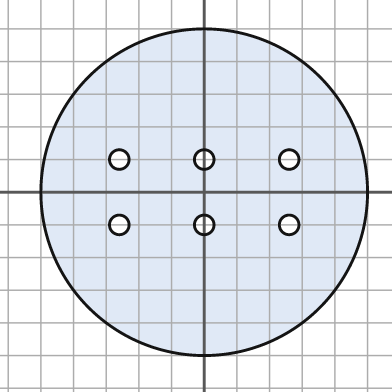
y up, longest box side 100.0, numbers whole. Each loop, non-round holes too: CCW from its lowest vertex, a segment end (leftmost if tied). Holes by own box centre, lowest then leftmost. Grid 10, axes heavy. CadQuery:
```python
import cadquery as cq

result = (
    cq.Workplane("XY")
    .moveTo(0.0, 0.0)
    .circle(50.0)
    .moveTo(-26.0, -10.0)
    .circle(3.0)
    .moveTo(0.0, -10.0)
    .circle(3.0)
    .moveTo(26.0, -10.0)
    .circle(3.0)
    .moveTo(-26.0, 10.0)
    .circle(3.0)
    .moveTo(0.0, 10.0)
    .circle(3.0)
    .moveTo(26.0, 10.0)
    .circle(3.0)
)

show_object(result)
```